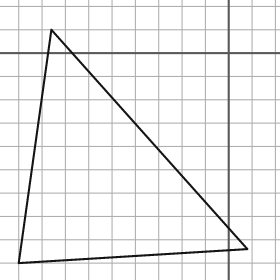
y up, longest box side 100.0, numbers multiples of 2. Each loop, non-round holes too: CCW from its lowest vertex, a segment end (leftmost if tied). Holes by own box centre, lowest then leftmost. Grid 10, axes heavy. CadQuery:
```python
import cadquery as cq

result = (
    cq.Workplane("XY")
    .moveTo(-90.0, -90.0)
    .lineTo(8.0, -84.0)
    .lineTo(-76.0, 10.0)
    .close()
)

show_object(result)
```